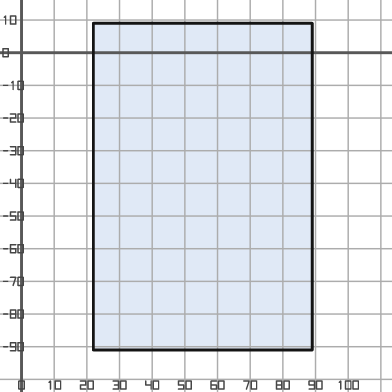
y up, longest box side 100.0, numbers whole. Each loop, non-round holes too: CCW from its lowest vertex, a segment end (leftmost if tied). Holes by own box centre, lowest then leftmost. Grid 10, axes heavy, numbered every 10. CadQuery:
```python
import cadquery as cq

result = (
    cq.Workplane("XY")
    .moveTo(22.0, -91.0)
    .lineTo(89.0, -91.0)
    .lineTo(89.0, 9.0)
    .lineTo(22.0, 9.0)
    .close()
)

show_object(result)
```